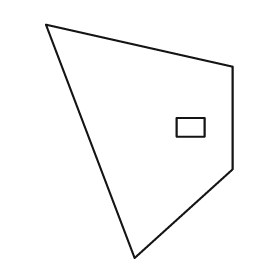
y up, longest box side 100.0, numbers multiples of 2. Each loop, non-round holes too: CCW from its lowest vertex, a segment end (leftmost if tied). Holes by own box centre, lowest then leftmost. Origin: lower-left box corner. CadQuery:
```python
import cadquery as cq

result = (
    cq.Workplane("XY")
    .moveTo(38.0, 0.0)
    .lineTo(80.0, 38.0)
    .lineTo(80.0, 82.0)
    .lineTo(0.0, 100.0)
    .close()
    .moveTo(56.0, 52.0)
    .lineTo(68.0, 52.0)
    .lineTo(68.0, 60.0)
    .lineTo(56.0, 60.0)
    .close()
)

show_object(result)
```